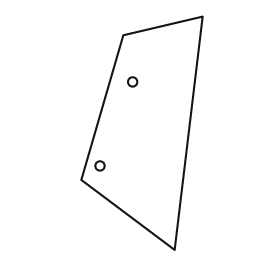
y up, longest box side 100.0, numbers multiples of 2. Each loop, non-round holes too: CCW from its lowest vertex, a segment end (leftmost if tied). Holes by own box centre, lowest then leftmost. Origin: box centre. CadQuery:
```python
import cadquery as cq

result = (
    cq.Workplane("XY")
    .moveTo(14.0, -50.0)
    .lineTo(26.0, 50.0)
    .lineTo(-8.0, 42.0)
    .lineTo(-26.0, -20.0)
    .close()
    .moveTo(-18.0, -14.0)
    .circle(2.0)
    .moveTo(-4.0, 22.0)
    .circle(2.0)
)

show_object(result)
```